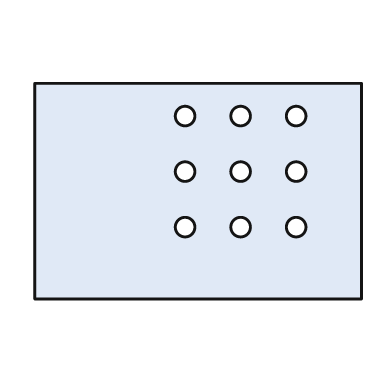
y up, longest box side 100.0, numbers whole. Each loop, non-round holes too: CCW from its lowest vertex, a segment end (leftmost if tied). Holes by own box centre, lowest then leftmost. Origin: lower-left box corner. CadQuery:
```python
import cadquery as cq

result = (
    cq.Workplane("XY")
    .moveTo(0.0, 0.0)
    .lineTo(100.0, 0.0)
    .lineTo(100.0, 66.0)
    .lineTo(0.0, 66.0)
    .close()
    .moveTo(46.0, 22.0)
    .circle(3.0)
    .moveTo(63.0, 22.0)
    .circle(3.0)
    .moveTo(80.0, 22.0)
    .circle(3.0)
    .moveTo(46.0, 39.0)
    .circle(3.0)
    .moveTo(63.0, 39.0)
    .circle(3.0)
    .moveTo(80.0, 39.0)
    .circle(3.0)
    .moveTo(46.0, 56.0)
    .circle(3.0)
    .moveTo(63.0, 56.0)
    .circle(3.0)
    .moveTo(80.0, 56.0)
    .circle(3.0)
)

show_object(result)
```